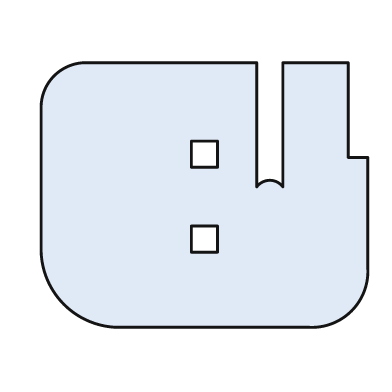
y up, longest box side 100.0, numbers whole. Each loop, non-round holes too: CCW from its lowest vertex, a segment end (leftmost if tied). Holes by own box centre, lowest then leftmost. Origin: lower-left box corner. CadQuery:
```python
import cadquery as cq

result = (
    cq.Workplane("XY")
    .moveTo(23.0, 0.0)
    .lineTo(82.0, 0.0)
    .threePointArc((95.0, 5.0), (100.0, 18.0))
    .lineTo(100.0, 52.0)
    .lineTo(94.0, 52.0)
    .lineTo(94.0, 81.0)
    .lineTo(74.0, 81.0)
    .lineTo(74.0, 43.0)
    .threePointArc((70.0, 45.0), (66.0, 43.0))
    .lineTo(66.0, 81.0)
    .lineTo(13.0, 81.0)
    .threePointArc((4.0, 77.0), (0.0, 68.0))
    .lineTo(0.0, 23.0)
    .threePointArc((7.0, 7.0), (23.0, 0.0))
    .close()
    .moveTo(46.0, 23.0)
    .lineTo(54.0, 23.0)
    .lineTo(54.0, 31.0)
    .lineTo(46.0, 31.0)
    .close()
    .moveTo(46.0, 49.0)
    .lineTo(54.0, 49.0)
    .lineTo(54.0, 57.0)
    .lineTo(46.0, 57.0)
    .close()
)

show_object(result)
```